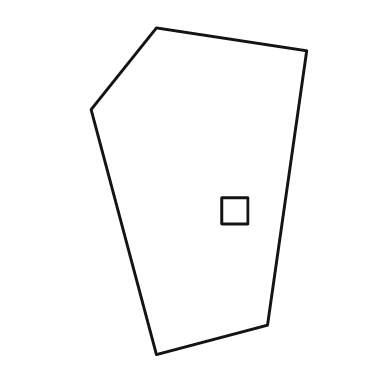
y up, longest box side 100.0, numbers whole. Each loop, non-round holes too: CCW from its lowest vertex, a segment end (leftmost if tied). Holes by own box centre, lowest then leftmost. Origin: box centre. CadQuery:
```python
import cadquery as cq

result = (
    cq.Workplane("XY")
    .moveTo(-13.0, -50.0)
    .lineTo(21.0, -41.0)
    .lineTo(33.0, 43.0)
    .lineTo(-13.0, 50.0)
    .lineTo(-33.0, 25.0)
    .close()
    .moveTo(7.0, -10.0)
    .lineTo(15.0, -10.0)
    .lineTo(15.0, -2.0)
    .lineTo(7.0, -2.0)
    .close()
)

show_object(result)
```